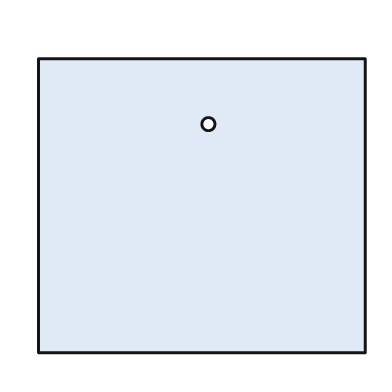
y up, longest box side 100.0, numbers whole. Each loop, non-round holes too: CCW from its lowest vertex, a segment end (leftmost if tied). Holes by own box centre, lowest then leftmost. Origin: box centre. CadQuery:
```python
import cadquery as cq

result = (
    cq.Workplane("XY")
    .moveTo(-50.0, -45.0)
    .lineTo(50.0, -45.0)
    .lineTo(50.0, 45.0)
    .lineTo(-50.0, 45.0)
    .close()
    .moveTo(2.0, 25.0)
    .circle(2.0)
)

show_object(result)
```